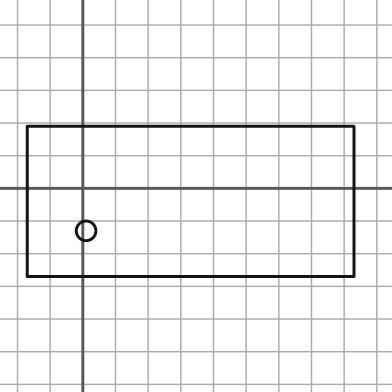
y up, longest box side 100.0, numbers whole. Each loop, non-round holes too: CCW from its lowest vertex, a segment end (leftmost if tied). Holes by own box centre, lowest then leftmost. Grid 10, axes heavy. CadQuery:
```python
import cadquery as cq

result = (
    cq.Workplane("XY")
    .moveTo(-17.0, -27.0)
    .lineTo(83.0, -27.0)
    .lineTo(83.0, 19.0)
    .lineTo(-17.0, 19.0)
    .close()
    .moveTo(1.0, -13.0)
    .circle(3.0)
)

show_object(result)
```